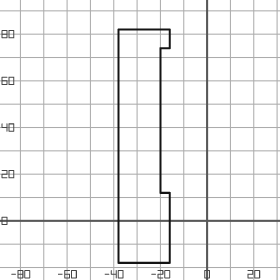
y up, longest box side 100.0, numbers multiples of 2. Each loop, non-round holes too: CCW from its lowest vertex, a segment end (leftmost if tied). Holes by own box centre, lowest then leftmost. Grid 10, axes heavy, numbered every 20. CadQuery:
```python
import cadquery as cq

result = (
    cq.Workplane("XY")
    .moveTo(-38.0, -18.0)
    .lineTo(-16.0, -18.0)
    .lineTo(-16.0, 12.0)
    .lineTo(-20.0, 12.0)
    .lineTo(-20.0, 74.0)
    .lineTo(-16.0, 74.0)
    .lineTo(-16.0, 82.0)
    .lineTo(-38.0, 82.0)
    .close()
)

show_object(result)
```